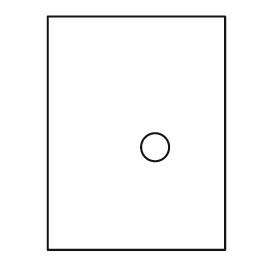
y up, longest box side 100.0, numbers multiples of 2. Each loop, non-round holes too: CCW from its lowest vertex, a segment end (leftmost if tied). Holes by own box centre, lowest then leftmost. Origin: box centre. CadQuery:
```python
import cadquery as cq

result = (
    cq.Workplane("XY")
    .moveTo(-38.0, -50.0)
    .lineTo(38.0, -50.0)
    .lineTo(38.0, 50.0)
    .lineTo(-38.0, 50.0)
    .close()
    .moveTo(8.0, -6.0)
    .circle(6.0)
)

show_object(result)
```